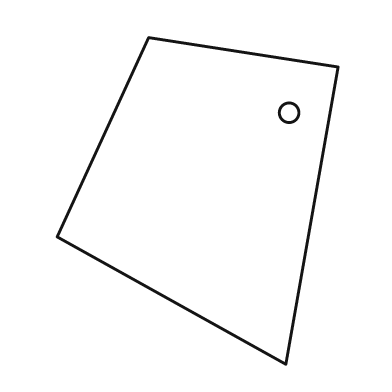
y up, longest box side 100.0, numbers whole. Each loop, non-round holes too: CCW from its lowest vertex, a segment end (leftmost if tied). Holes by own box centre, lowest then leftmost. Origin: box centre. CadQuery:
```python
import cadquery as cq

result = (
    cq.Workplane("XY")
    .moveTo(27.0, -50.0)
    .lineTo(43.0, 41.0)
    .lineTo(-15.0, 50.0)
    .lineTo(-43.0, -11.0)
    .close()
    .moveTo(28.0, 27.0)
    .circle(3.0)
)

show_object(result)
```